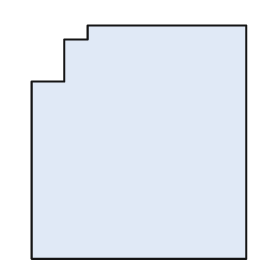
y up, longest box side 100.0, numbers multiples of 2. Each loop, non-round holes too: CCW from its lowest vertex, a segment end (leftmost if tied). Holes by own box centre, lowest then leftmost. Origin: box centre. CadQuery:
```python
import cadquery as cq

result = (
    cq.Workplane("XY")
    .moveTo(-46.0, -50.0)
    .lineTo(46.0, -50.0)
    .lineTo(46.0, 50.0)
    .lineTo(-22.0, 50.0)
    .lineTo(-22.0, 44.0)
    .lineTo(-32.0, 44.0)
    .lineTo(-32.0, 26.0)
    .lineTo(-46.0, 26.0)
    .close()
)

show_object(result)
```